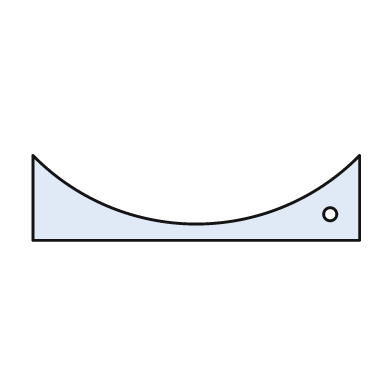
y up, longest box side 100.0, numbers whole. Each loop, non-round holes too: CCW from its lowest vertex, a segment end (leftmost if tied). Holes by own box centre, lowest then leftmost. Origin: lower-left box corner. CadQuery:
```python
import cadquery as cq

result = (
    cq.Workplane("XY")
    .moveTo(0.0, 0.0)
    .lineTo(100.0, 0.0)
    .lineTo(100.0, 26.0)
    .threePointArc((50.0, 5.0), (0.0, 26.0))
    .close()
    .moveTo(91.0, 8.0)
    .circle(2.0)
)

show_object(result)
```